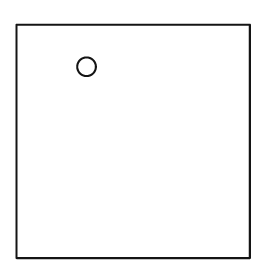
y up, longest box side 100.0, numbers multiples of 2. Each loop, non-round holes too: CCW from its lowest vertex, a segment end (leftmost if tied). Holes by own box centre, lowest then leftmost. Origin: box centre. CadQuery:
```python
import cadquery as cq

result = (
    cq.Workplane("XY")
    .moveTo(-50.0, -50.0)
    .lineTo(50.0, -50.0)
    .lineTo(50.0, 50.0)
    .lineTo(-50.0, 50.0)
    .close()
    .moveTo(-20.0, 32.0)
    .circle(4.0)
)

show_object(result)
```